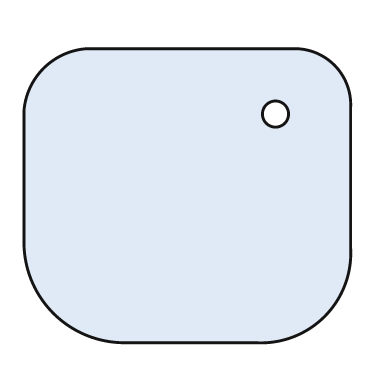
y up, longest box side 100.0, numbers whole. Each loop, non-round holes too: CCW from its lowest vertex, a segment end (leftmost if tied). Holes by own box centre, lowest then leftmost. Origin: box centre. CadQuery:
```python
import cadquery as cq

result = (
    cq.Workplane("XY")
    .moveTo(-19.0, -45.0)
    .lineTo(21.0, -45.0)
    .threePointArc((42.0, -37.0), (50.0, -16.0))
    .lineTo(50.0, 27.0)
    .threePointArc((45.0, 40.0), (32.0, 45.0))
    .lineTo(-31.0, 45.0)
    .threePointArc((-44.0, 39.0), (-50.0, 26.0))
    .lineTo(-50.0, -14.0)
    .threePointArc((-41.0, -36.0), (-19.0, -45.0))
    .close()
    .moveTo(27.0, 25.0)
    .circle(4.0)
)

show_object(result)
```